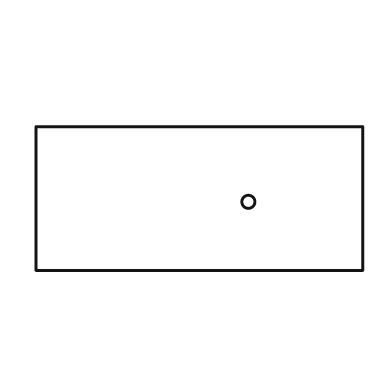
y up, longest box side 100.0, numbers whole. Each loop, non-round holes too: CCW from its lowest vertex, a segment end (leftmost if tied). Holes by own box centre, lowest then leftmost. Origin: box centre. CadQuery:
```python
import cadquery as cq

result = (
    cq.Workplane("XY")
    .moveTo(-50.0, -22.0)
    .lineTo(50.0, -22.0)
    .lineTo(50.0, 22.0)
    .lineTo(-50.0, 22.0)
    .close()
    .moveTo(15.0, -1.0)
    .circle(2.0)
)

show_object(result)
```